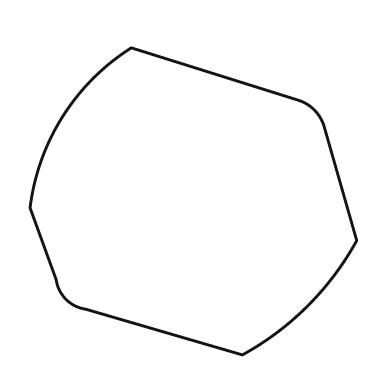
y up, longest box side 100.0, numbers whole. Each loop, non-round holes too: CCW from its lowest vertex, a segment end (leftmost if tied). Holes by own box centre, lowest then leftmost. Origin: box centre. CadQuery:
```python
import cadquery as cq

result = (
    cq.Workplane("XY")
    .moveTo(15.0, -47.0)
    .threePointArc((35.0, -32.0), (50.0, -12.0))
    .lineTo(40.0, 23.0)
    .threePointArc((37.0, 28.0), (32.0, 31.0))
    .lineTo(-19.0, 47.0)
    .threePointArc((-40.0, 26.0), (-50.0, -2.0))
    .lineTo(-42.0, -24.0)
    .threePointArc((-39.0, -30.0), (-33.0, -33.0))
    .close()
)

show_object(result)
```